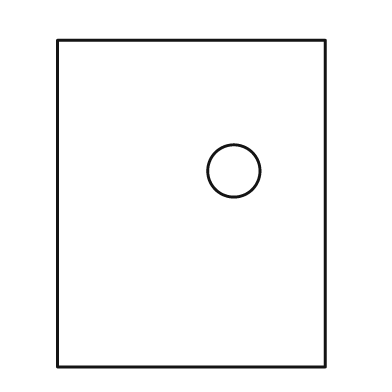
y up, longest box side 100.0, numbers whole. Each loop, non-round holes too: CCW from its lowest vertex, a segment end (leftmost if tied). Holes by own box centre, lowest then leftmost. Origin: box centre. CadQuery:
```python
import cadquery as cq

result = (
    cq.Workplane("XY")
    .moveTo(-41.0, -50.0)
    .lineTo(41.0, -50.0)
    .lineTo(41.0, 50.0)
    .lineTo(-41.0, 50.0)
    .close()
    .moveTo(13.0, 10.0)
    .circle(8.0)
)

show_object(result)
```